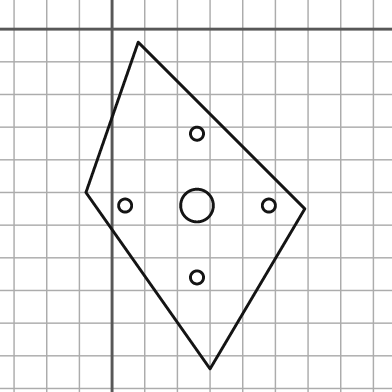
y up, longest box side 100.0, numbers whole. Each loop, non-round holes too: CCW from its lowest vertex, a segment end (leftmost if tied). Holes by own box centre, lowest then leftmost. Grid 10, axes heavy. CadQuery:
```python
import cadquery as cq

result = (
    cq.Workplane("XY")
    .moveTo(30.0, -104.0)
    .lineTo(59.0, -55.0)
    .lineTo(8.0, -4.0)
    .lineTo(-8.0, -50.0)
    .close()
    .moveTo(26.0, -76.0)
    .circle(2.0)
    .moveTo(4.0, -54.0)
    .circle(2.0)
    .moveTo(26.0, -54.0)
    .circle(5.0)
    .moveTo(48.0, -54.0)
    .circle(2.0)
    .moveTo(26.0, -32.0)
    .circle(2.0)
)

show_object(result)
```